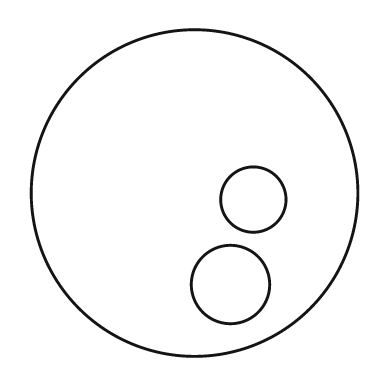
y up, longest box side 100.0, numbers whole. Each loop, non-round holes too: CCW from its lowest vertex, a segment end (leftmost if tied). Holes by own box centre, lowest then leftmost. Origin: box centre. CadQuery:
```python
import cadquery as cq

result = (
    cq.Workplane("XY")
    .moveTo(0.0, 0.0)
    .circle(50.0)
    .moveTo(11.0, -28.0)
    .circle(12.0)
    .moveTo(18.0, -2.0)
    .circle(10.0)
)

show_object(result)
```